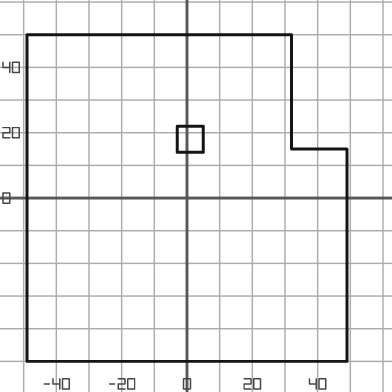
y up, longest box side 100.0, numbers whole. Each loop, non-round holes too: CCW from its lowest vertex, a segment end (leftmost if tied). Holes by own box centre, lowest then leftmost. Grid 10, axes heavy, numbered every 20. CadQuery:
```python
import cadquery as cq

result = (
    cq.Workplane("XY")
    .moveTo(-49.0, -50.0)
    .lineTo(49.0, -50.0)
    .lineTo(49.0, 15.0)
    .lineTo(32.0, 15.0)
    .lineTo(32.0, 50.0)
    .lineTo(-49.0, 50.0)
    .close()
    .moveTo(-3.0, 14.0)
    .lineTo(5.0, 14.0)
    .lineTo(5.0, 22.0)
    .lineTo(-3.0, 22.0)
    .close()
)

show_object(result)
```